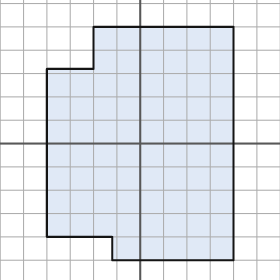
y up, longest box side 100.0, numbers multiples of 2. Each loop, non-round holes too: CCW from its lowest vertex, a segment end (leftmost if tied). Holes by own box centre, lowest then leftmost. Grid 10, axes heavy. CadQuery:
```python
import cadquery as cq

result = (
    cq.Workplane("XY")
    .moveTo(-12.0, -50.0)
    .lineTo(40.0, -50.0)
    .lineTo(40.0, 50.0)
    .lineTo(-20.0, 50.0)
    .lineTo(-20.0, 32.0)
    .lineTo(-40.0, 32.0)
    .lineTo(-40.0, -40.0)
    .lineTo(-12.0, -40.0)
    .close()
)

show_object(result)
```